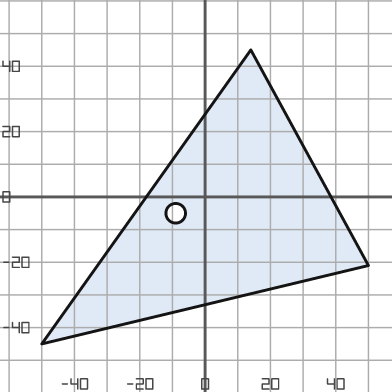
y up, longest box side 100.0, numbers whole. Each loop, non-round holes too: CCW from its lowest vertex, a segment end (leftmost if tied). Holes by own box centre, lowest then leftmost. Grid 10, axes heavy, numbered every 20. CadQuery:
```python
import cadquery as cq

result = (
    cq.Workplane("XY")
    .moveTo(-50.0, -45.0)
    .lineTo(50.0, -21.0)
    .lineTo(14.0, 45.0)
    .close()
    .moveTo(-9.0, -5.0)
    .circle(3.0)
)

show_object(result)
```